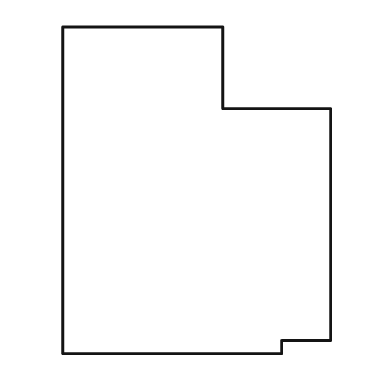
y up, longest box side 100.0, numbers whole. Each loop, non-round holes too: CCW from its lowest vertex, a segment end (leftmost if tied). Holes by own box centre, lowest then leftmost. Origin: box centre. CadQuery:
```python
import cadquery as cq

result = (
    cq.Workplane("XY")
    .moveTo(-41.0, -50.0)
    .lineTo(26.0, -50.0)
    .lineTo(26.0, -46.0)
    .lineTo(41.0, -46.0)
    .lineTo(41.0, 25.0)
    .lineTo(8.0, 25.0)
    .lineTo(8.0, 50.0)
    .lineTo(-41.0, 50.0)
    .close()
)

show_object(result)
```